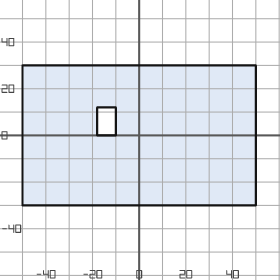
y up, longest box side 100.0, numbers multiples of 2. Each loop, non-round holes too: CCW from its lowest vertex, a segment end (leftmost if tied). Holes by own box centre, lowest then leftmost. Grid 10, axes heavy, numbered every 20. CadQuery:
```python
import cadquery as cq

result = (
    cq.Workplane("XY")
    .moveTo(-50.0, -30.0)
    .lineTo(50.0, -30.0)
    .lineTo(50.0, 30.0)
    .lineTo(-50.0, 30.0)
    .close()
    .moveTo(-18.0, 0.0)
    .lineTo(-10.0, 0.0)
    .lineTo(-10.0, 12.0)
    .lineTo(-18.0, 12.0)
    .close()
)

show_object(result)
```